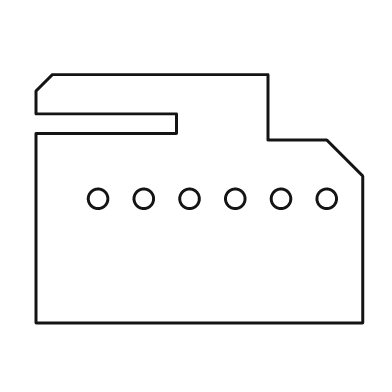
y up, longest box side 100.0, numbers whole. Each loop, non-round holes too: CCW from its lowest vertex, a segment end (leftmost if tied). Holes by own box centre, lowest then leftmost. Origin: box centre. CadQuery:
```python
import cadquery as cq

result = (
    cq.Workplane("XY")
    .moveTo(-50.0, -38.0)
    .lineTo(50.0, -38.0)
    .lineTo(50.0, 7.0)
    .lineTo(39.0, 18.0)
    .lineTo(21.0, 18.0)
    .lineTo(21.0, 38.0)
    .lineTo(-45.0, 38.0)
    .lineTo(-50.0, 33.0)
    .lineTo(-50.0, 26.0)
    .lineTo(-7.0, 26.0)
    .lineTo(-7.0, 20.0)
    .lineTo(-50.0, 20.0)
    .close()
    .moveTo(-31.0, 0.0)
    .circle(3.0)
    .moveTo(-17.0, 0.0)
    .circle(3.0)
    .moveTo(-3.0, 0.0)
    .circle(3.0)
    .moveTo(11.0, 0.0)
    .circle(3.0)
    .moveTo(25.0, 0.0)
    .circle(3.0)
    .moveTo(39.0, 0.0)
    .circle(3.0)
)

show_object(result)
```